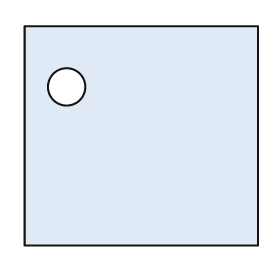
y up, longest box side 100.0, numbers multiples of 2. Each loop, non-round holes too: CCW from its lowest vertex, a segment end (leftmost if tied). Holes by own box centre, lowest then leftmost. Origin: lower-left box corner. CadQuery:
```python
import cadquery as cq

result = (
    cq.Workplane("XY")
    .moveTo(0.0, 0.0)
    .lineTo(100.0, 0.0)
    .lineTo(100.0, 94.0)
    .lineTo(0.0, 94.0)
    .close()
    .moveTo(18.0, 68.0)
    .circle(8.0)
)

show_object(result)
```